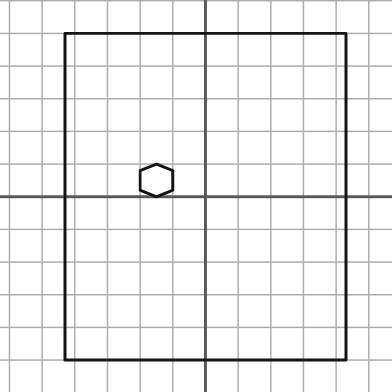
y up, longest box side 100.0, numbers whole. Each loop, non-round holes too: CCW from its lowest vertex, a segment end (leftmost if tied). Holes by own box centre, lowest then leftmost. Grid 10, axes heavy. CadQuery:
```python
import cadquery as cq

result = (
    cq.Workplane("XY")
    .moveTo(-43.0, -50.0)
    .lineTo(43.0, -50.0)
    .lineTo(43.0, 50.0)
    .lineTo(-43.0, 50.0)
    .close()
    .moveTo(-15.0, 0.0)
    .lineTo(-10.0, 2.0)
    .lineTo(-10.0, 8.0)
    .lineTo(-15.0, 10.0)
    .lineTo(-20.0, 8.0)
    .lineTo(-20.0, 2.0)
    .close()
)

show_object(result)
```